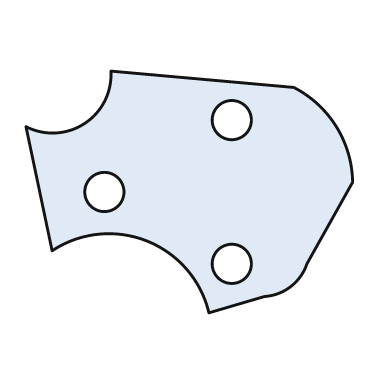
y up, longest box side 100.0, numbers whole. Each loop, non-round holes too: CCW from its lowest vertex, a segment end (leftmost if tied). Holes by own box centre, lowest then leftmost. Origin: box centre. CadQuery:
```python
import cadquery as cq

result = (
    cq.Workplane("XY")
    .moveTo(6.0, -37.0)
    .lineTo(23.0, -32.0)
    .threePointArc((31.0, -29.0), (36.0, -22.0))
    .lineTo(50.0, 3.0)
    .threePointArc((45.0, 20.0), (32.0, 32.0))
    .lineTo(-24.0, 37.0)
    .threePointArc((-32.0, 21.0), (-50.0, 20.0))
    .lineTo(-42.0, -18.0)
    .threePointArc((-13.0, -15.0), (6.0, -37.0))
    .close()
    .moveTo(13.0, -22.0)
    .circle(6.0)
    .moveTo(-26.0, 0.0)
    .circle(6.0)
    .moveTo(13.0, 22.0)
    .circle(6.0)
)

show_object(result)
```